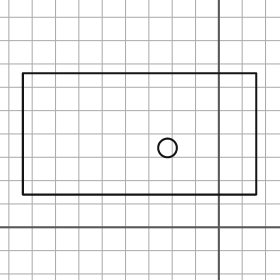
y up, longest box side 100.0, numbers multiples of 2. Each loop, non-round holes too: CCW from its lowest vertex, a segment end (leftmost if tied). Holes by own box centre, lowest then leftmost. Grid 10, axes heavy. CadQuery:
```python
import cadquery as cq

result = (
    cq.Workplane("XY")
    .moveTo(-84.0, 14.0)
    .lineTo(16.0, 14.0)
    .lineTo(16.0, 66.0)
    .lineTo(-84.0, 66.0)
    .close()
    .moveTo(-22.0, 34.0)
    .circle(4.0)
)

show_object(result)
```